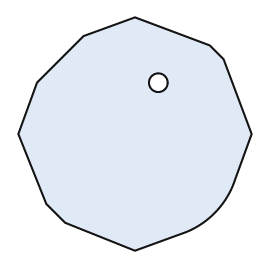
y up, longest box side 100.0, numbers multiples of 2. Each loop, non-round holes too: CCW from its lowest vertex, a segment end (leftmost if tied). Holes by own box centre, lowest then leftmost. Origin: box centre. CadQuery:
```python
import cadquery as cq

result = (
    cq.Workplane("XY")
    .moveTo(0.0, -50.0)
    .lineTo(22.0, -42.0)
    .threePointArc((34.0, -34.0), (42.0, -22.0))
    .lineTo(50.0, 0.0)
    .lineTo(38.0, 32.0)
    .lineTo(32.0, 38.0)
    .lineTo(0.0, 50.0)
    .lineTo(-22.0, 42.0)
    .lineTo(-42.0, 22.0)
    .lineTo(-50.0, 0.0)
    .lineTo(-38.0, -30.0)
    .lineTo(-30.0, -38.0)
    .close()
    .moveTo(10.0, 22.0)
    .circle(4.0)
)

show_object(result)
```